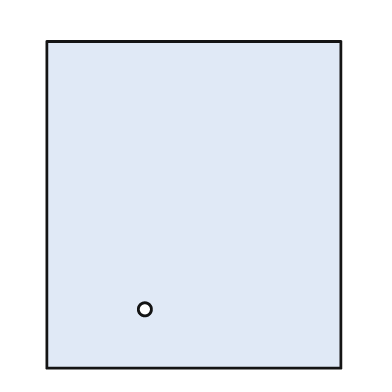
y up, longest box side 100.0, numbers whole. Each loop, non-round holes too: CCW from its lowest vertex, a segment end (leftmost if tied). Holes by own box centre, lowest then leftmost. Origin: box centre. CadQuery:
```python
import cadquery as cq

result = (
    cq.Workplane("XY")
    .moveTo(-45.0, -50.0)
    .lineTo(45.0, -50.0)
    .lineTo(45.0, 50.0)
    .lineTo(-45.0, 50.0)
    .close()
    .moveTo(-15.0, -32.0)
    .circle(2.0)
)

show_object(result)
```